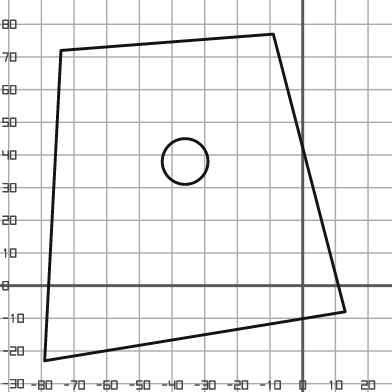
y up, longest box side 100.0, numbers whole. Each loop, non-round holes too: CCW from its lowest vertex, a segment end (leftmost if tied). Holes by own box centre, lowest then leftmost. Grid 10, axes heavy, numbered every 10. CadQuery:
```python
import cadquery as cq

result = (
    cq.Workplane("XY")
    .moveTo(-79.0, -23.0)
    .lineTo(13.0, -8.0)
    .lineTo(-9.0, 77.0)
    .lineTo(-74.0, 72.0)
    .close()
    .moveTo(-36.0, 38.0)
    .circle(7.0)
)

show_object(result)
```